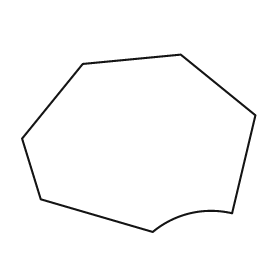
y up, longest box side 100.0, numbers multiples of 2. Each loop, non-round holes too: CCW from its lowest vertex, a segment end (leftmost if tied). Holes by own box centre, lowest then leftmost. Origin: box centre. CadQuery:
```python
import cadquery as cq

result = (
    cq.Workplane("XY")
    .moveTo(6.0, -38.0)
    .threePointArc((22.0, -30.0), (40.0, -30.0))
    .lineTo(50.0, 12.0)
    .lineTo(18.0, 38.0)
    .lineTo(-24.0, 34.0)
    .lineTo(-50.0, 2.0)
    .lineTo(-42.0, -24.0)
    .close()
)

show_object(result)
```